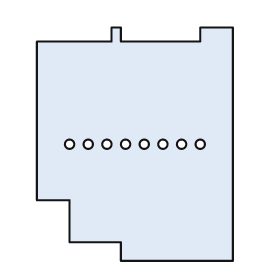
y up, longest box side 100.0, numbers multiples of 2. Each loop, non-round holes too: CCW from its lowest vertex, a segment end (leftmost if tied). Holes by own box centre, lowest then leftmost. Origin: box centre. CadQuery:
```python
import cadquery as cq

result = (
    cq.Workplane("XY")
    .moveTo(-6.0, -50.0)
    .lineTo(42.0, -50.0)
    .lineTo(42.0, 50.0)
    .lineTo(28.0, 50.0)
    .lineTo(28.0, 44.0)
    .lineTo(-6.0, 44.0)
    .lineTo(-6.0, 50.0)
    .lineTo(-10.0, 50.0)
    .lineTo(-10.0, 44.0)
    .lineTo(-42.0, 44.0)
    .lineTo(-42.0, -24.0)
    .lineTo(-28.0, -24.0)
    .lineTo(-28.0, -42.0)
    .lineTo(-6.0, -42.0)
    .close()
    .moveTo(-28.0, 0.0)
    .circle(2.0)
    .moveTo(-20.0, 0.0)
    .circle(2.0)
    .moveTo(-12.0, 0.0)
    .circle(2.0)
    .moveTo(-4.0, 0.0)
    .circle(2.0)
    .moveTo(4.0, 0.0)
    .circle(2.0)
    .moveTo(12.0, 0.0)
    .circle(2.0)
    .moveTo(20.0, 0.0)
    .circle(2.0)
    .moveTo(28.0, 0.0)
    .circle(2.0)
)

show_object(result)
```